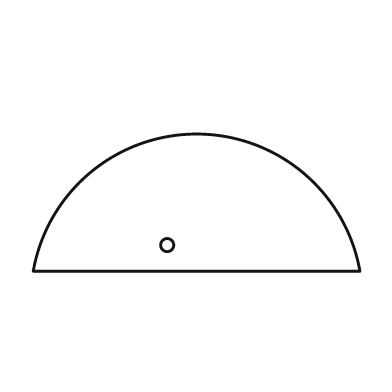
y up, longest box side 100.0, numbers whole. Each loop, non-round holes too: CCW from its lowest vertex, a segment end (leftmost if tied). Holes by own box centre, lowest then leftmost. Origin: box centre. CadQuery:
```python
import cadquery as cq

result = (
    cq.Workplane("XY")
    .moveTo(-50.0, -21.0)
    .lineTo(50.0, -21.0)
    .threePointArc((0.0, 21.0), (-50.0, -21.0))
    .close()
    .moveTo(-9.0, -13.0)
    .circle(2.0)
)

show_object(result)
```